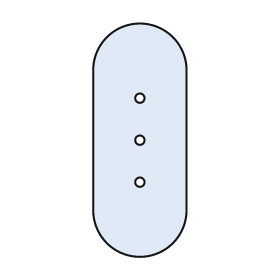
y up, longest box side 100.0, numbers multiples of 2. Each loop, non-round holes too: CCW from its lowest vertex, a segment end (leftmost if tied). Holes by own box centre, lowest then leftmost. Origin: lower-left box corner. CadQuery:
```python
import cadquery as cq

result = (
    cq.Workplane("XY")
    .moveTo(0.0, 20.0)
    .threePointArc((20.0, 0.0), (40.0, 20.0))
    .lineTo(40.0, 80.0)
    .threePointArc((20.0, 100.0), (0.0, 80.0))
    .close()
    .moveTo(20.0, 32.0)
    .circle(2.0)
    .moveTo(20.0, 50.0)
    .circle(2.0)
    .moveTo(20.0, 68.0)
    .circle(2.0)
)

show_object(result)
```